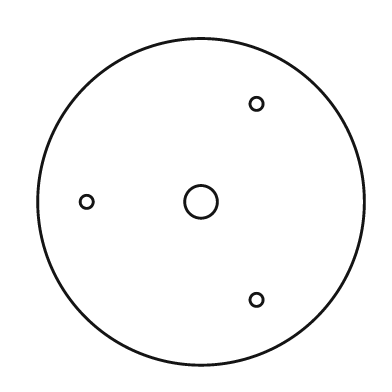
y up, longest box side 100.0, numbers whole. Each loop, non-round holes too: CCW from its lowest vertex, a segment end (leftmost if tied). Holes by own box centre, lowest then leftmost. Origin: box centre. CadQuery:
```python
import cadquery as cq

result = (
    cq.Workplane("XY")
    .moveTo(0.0, 0.0)
    .circle(50.0)
    .moveTo(17.0, -30.0)
    .circle(2.0)
    .moveTo(-35.0, 0.0)
    .circle(2.0)
    .moveTo(0.0, 0.0)
    .circle(5.0)
    .moveTo(17.0, 30.0)
    .circle(2.0)
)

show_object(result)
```